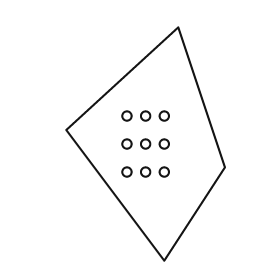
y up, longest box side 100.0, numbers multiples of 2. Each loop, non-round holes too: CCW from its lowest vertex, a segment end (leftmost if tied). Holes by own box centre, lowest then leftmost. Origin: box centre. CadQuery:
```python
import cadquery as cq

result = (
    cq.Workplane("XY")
    .moveTo(8.0, -50.0)
    .lineTo(34.0, -10.0)
    .lineTo(14.0, 50.0)
    .lineTo(-34.0, 6.0)
    .close()
    .moveTo(-8.0, -12.0)
    .circle(2.0)
    .moveTo(0.0, -12.0)
    .circle(2.0)
    .moveTo(8.0, -12.0)
    .circle(2.0)
    .moveTo(-8.0, 0.0)
    .circle(2.0)
    .moveTo(0.0, 0.0)
    .circle(2.0)
    .moveTo(8.0, 0.0)
    .circle(2.0)
    .moveTo(-8.0, 12.0)
    .circle(2.0)
    .moveTo(0.0, 12.0)
    .circle(2.0)
    .moveTo(8.0, 12.0)
    .circle(2.0)
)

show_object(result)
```